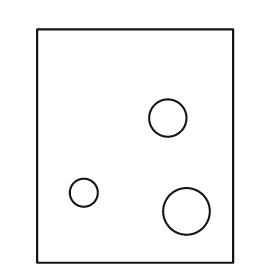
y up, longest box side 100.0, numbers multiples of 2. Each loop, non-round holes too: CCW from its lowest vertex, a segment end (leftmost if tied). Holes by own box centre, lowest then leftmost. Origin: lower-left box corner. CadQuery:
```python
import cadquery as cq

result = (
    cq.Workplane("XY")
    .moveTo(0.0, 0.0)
    .lineTo(84.0, 0.0)
    .lineTo(84.0, 100.0)
    .lineTo(0.0, 100.0)
    .close()
    .moveTo(64.0, 22.0)
    .circle(10.0)
    .moveTo(20.0, 30.0)
    .circle(6.0)
    .moveTo(56.0, 62.0)
    .circle(8.0)
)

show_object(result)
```